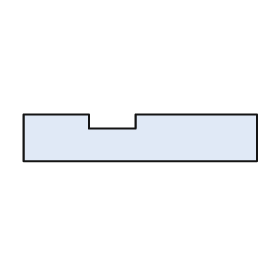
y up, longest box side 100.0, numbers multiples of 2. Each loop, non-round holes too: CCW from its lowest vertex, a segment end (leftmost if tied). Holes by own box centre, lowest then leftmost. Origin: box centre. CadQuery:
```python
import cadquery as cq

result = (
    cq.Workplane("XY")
    .moveTo(-50.0, -10.0)
    .lineTo(50.0, -10.0)
    .lineTo(50.0, 10.0)
    .lineTo(-2.0, 10.0)
    .lineTo(-2.0, 4.0)
    .lineTo(-22.0, 4.0)
    .lineTo(-22.0, 10.0)
    .lineTo(-50.0, 10.0)
    .close()
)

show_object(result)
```